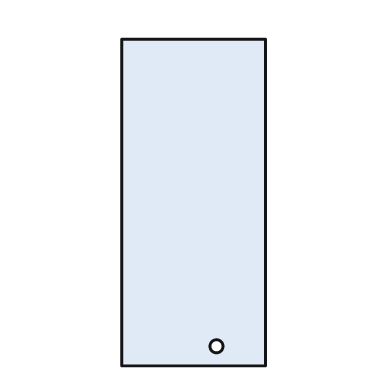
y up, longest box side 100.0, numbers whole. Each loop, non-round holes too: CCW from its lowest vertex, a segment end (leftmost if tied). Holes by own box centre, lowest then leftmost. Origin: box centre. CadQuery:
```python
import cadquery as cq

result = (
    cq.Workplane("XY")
    .moveTo(-22.0, -50.0)
    .lineTo(22.0, -50.0)
    .lineTo(22.0, 50.0)
    .lineTo(-22.0, 50.0)
    .close()
    .moveTo(7.0, -44.0)
    .circle(2.0)
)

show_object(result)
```